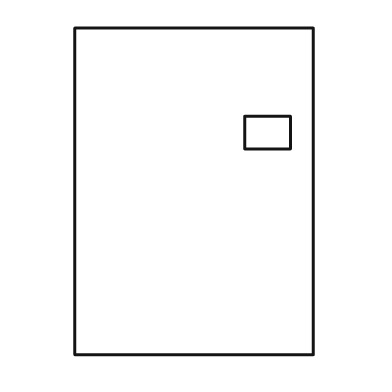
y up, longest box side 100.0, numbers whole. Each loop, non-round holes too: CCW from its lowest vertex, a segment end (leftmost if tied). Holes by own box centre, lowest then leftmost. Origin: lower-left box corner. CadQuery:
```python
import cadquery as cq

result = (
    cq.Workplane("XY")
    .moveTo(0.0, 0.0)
    .lineTo(73.0, 0.0)
    .lineTo(73.0, 100.0)
    .lineTo(0.0, 100.0)
    .close()
    .moveTo(52.0, 63.0)
    .lineTo(66.0, 63.0)
    .lineTo(66.0, 73.0)
    .lineTo(52.0, 73.0)
    .close()
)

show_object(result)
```